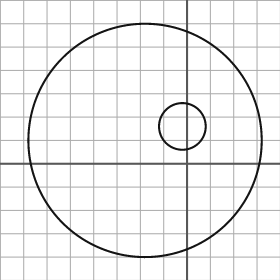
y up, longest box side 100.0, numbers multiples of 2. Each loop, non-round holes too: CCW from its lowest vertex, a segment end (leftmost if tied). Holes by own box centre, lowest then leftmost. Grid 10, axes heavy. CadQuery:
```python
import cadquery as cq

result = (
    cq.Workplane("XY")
    .moveTo(-18.0, 10.0)
    .circle(50.0)
    .moveTo(-2.0, 16.0)
    .circle(10.0)
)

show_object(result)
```